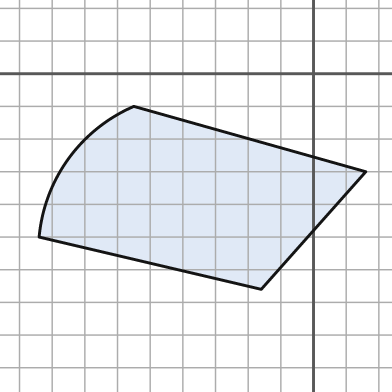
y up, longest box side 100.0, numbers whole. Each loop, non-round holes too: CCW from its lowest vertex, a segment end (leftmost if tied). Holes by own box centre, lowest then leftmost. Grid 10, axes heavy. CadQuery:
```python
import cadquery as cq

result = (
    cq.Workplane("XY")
    .moveTo(-16.0, -66.0)
    .lineTo(16.0, -30.0)
    .lineTo(-55.0, -10.0)
    .threePointArc((-75.0, -26.0), (-84.0, -50.0))
    .close()
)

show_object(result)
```